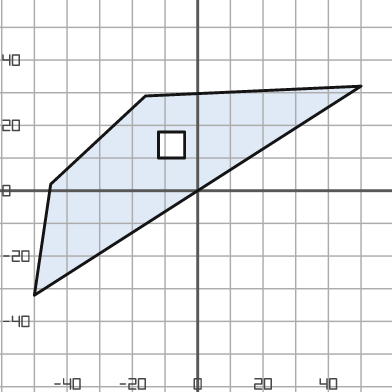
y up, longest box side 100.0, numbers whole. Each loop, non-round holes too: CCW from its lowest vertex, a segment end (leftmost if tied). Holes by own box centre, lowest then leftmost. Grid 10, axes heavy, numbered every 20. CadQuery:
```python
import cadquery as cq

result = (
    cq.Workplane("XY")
    .moveTo(-50.0, -32.0)
    .lineTo(50.0, 32.0)
    .lineTo(-16.0, 29.0)
    .lineTo(-45.0, 2.0)
    .close()
    .moveTo(-12.0, 10.0)
    .lineTo(-4.0, 10.0)
    .lineTo(-4.0, 18.0)
    .lineTo(-12.0, 18.0)
    .close()
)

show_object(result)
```